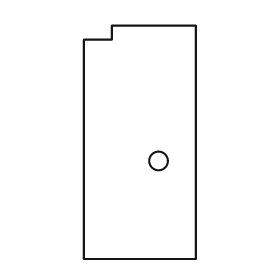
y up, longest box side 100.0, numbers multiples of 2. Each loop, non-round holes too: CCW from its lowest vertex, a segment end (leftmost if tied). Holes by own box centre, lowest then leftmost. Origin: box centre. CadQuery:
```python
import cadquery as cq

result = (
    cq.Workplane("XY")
    .moveTo(-24.0, -50.0)
    .lineTo(24.0, -50.0)
    .lineTo(24.0, 50.0)
    .lineTo(-12.0, 50.0)
    .lineTo(-12.0, 44.0)
    .lineTo(-24.0, 44.0)
    .close()
    .moveTo(8.0, -8.0)
    .circle(4.0)
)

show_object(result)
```